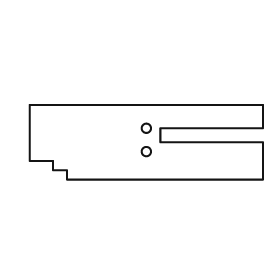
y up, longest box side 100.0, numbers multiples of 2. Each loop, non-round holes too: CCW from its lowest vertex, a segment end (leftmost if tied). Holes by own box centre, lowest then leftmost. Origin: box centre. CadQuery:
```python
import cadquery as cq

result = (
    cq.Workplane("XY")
    .moveTo(-34.0, -16.0)
    .lineTo(50.0, -16.0)
    .lineTo(50.0, 0.0)
    .lineTo(6.0, 0.0)
    .lineTo(6.0, 6.0)
    .lineTo(50.0, 6.0)
    .lineTo(50.0, 16.0)
    .lineTo(-50.0, 16.0)
    .lineTo(-50.0, -8.0)
    .lineTo(-40.0, -8.0)
    .lineTo(-40.0, -12.0)
    .lineTo(-34.0, -12.0)
    .close()
    .moveTo(0.0, -4.0)
    .circle(2.0)
    .moveTo(0.0, 6.0)
    .circle(2.0)
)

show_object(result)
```